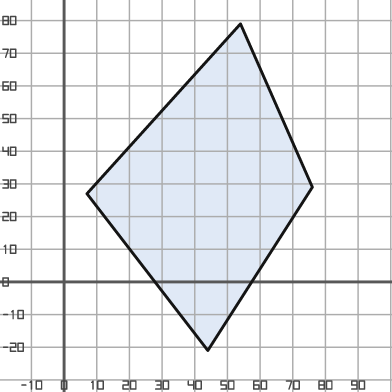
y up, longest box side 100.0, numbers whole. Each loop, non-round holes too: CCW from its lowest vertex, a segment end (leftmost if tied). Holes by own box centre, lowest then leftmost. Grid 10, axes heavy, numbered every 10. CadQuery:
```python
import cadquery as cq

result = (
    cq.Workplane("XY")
    .moveTo(44.0, -21.0)
    .lineTo(76.0, 29.0)
    .lineTo(54.0, 79.0)
    .lineTo(7.0, 27.0)
    .close()
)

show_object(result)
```